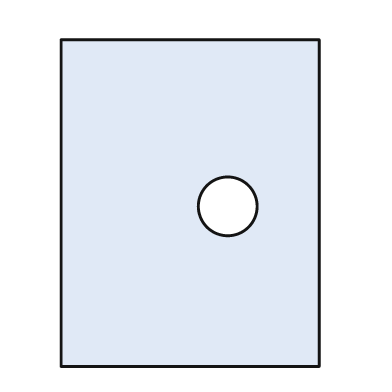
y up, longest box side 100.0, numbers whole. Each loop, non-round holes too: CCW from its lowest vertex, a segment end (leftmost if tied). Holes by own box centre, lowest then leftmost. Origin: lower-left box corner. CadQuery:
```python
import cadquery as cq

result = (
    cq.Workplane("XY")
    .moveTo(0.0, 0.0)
    .lineTo(79.0, 0.0)
    .lineTo(79.0, 100.0)
    .lineTo(0.0, 100.0)
    .close()
    .moveTo(51.0, 49.0)
    .circle(9.0)
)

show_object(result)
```